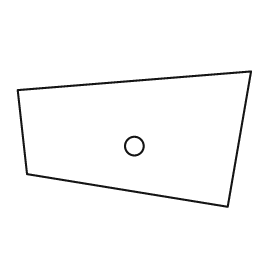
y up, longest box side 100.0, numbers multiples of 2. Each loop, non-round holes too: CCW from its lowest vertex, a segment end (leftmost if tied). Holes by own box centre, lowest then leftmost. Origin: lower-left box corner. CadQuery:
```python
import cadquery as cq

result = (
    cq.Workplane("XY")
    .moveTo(90.0, 0.0)
    .lineTo(100.0, 58.0)
    .lineTo(0.0, 50.0)
    .lineTo(4.0, 14.0)
    .close()
    .moveTo(50.0, 26.0)
    .circle(4.0)
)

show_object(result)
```